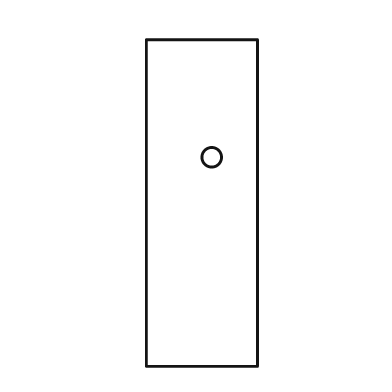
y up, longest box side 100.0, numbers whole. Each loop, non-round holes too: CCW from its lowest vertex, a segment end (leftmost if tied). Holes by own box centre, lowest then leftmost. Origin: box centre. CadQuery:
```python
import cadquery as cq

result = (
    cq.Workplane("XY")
    .moveTo(-17.0, -50.0)
    .lineTo(17.0, -50.0)
    .lineTo(17.0, 50.0)
    .lineTo(-17.0, 50.0)
    .close()
    .moveTo(3.0, 14.0)
    .circle(3.0)
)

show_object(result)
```